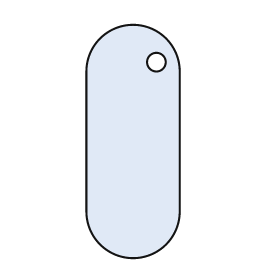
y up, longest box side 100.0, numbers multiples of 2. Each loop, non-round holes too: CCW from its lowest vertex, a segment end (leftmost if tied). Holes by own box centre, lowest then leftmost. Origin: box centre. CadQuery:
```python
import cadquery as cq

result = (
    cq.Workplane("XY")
    .moveTo(-20.0, -30.0)
    .threePointArc((0.0, -50.0), (20.0, -30.0))
    .lineTo(20.0, 30.0)
    .threePointArc((0.0, 50.0), (-20.0, 30.0))
    .close()
    .moveTo(10.0, 34.0)
    .circle(4.0)
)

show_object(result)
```